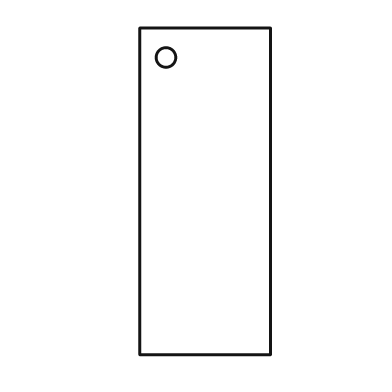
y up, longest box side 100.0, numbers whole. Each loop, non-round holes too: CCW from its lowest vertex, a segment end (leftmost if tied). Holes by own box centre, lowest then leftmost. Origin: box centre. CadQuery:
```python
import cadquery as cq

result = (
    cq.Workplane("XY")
    .moveTo(-20.0, -50.0)
    .lineTo(20.0, -50.0)
    .lineTo(20.0, 50.0)
    .lineTo(-20.0, 50.0)
    .close()
    .moveTo(-12.0, 41.0)
    .circle(3.0)
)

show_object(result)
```